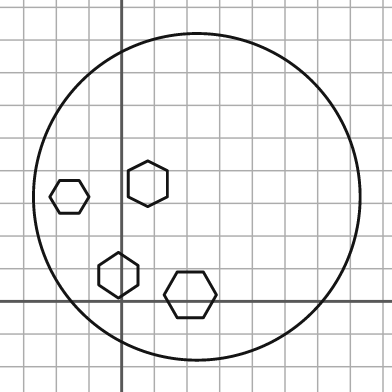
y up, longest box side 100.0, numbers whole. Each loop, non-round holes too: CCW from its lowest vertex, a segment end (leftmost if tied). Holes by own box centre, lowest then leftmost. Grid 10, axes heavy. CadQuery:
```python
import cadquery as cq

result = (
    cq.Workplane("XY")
    .moveTo(23.0, 32.0)
    .circle(50.0)
    .moveTo(17.0, -5.0)
    .lineTo(25.0, -5.0)
    .lineTo(29.0, 2.0)
    .lineTo(25.0, 9.0)
    .lineTo(17.0, 9.0)
    .lineTo(13.0, 2.0)
    .close()
    .moveTo(-1.0, 1.0)
    .lineTo(5.0, 5.0)
    .lineTo(5.0, 11.0)
    .lineTo(-1.0, 15.0)
    .lineTo(-7.0, 11.0)
    .lineTo(-7.0, 5.0)
    .close()
    .moveTo(-19.0, 27.0)
    .lineTo(-13.0, 27.0)
    .lineTo(-10.0, 32.0)
    .lineTo(-13.0, 37.0)
    .lineTo(-19.0, 37.0)
    .lineTo(-22.0, 32.0)
    .close()
    .moveTo(8.0, 29.0)
    .lineTo(14.0, 32.0)
    .lineTo(14.0, 40.0)
    .lineTo(8.0, 43.0)
    .lineTo(2.0, 40.0)
    .lineTo(2.0, 32.0)
    .close()
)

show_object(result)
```